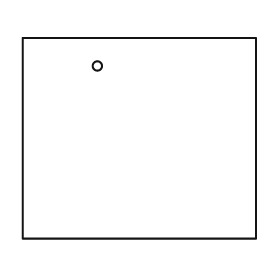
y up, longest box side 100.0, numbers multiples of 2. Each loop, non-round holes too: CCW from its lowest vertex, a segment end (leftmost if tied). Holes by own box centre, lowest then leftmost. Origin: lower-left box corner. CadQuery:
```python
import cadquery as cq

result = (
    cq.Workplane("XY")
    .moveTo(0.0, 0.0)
    .lineTo(100.0, 0.0)
    .lineTo(100.0, 86.0)
    .lineTo(0.0, 86.0)
    .close()
    .moveTo(32.0, 74.0)
    .circle(2.0)
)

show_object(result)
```